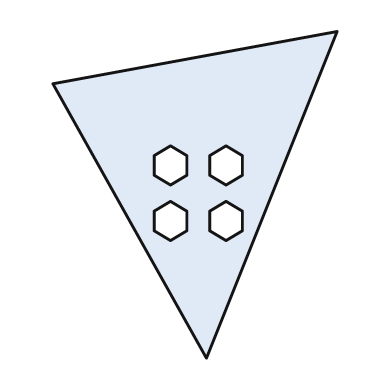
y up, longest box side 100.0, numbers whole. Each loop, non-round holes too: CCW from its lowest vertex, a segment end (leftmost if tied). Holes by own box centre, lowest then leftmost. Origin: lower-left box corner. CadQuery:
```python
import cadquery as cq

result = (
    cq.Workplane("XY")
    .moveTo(47.0, 0.0)
    .lineTo(87.0, 100.0)
    .lineTo(0.0, 84.0)
    .close()
    .moveTo(36.0, 36.0)
    .lineTo(41.0, 39.0)
    .lineTo(41.0, 45.0)
    .lineTo(36.0, 48.0)
    .lineTo(31.0, 45.0)
    .lineTo(31.0, 39.0)
    .close()
    .moveTo(53.0, 36.0)
    .lineTo(58.0, 39.0)
    .lineTo(58.0, 45.0)
    .lineTo(53.0, 48.0)
    .lineTo(48.0, 45.0)
    .lineTo(48.0, 39.0)
    .close()
    .moveTo(36.0, 53.0)
    .lineTo(41.0, 56.0)
    .lineTo(41.0, 62.0)
    .lineTo(36.0, 65.0)
    .lineTo(31.0, 62.0)
    .lineTo(31.0, 56.0)
    .close()
    .moveTo(53.0, 53.0)
    .lineTo(58.0, 56.0)
    .lineTo(58.0, 62.0)
    .lineTo(53.0, 65.0)
    .lineTo(48.0, 62.0)
    .lineTo(48.0, 56.0)
    .close()
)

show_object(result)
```